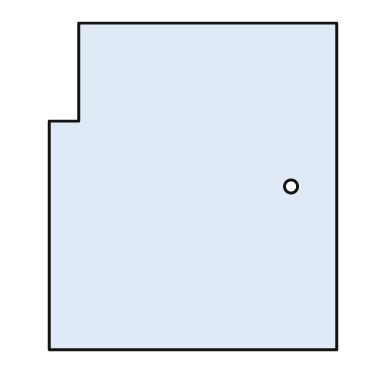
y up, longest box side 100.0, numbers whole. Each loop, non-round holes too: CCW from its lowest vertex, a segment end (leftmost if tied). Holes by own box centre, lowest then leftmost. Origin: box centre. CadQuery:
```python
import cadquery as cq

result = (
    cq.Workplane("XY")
    .moveTo(-44.0, -50.0)
    .lineTo(44.0, -50.0)
    .lineTo(44.0, 50.0)
    .lineTo(-35.0, 50.0)
    .lineTo(-35.0, 20.0)
    .lineTo(-44.0, 20.0)
    .close()
    .moveTo(30.0, 0.0)
    .circle(2.0)
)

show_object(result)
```